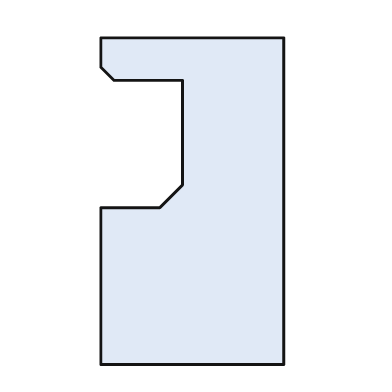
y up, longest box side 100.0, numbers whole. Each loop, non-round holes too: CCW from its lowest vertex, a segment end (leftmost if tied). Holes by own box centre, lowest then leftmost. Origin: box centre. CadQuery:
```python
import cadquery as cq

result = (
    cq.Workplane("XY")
    .moveTo(-28.0, -50.0)
    .lineTo(28.0, -50.0)
    .lineTo(28.0, 50.0)
    .lineTo(-28.0, 50.0)
    .lineTo(-28.0, 41.0)
    .lineTo(-24.0, 37.0)
    .lineTo(-3.0, 37.0)
    .lineTo(-3.0, 5.0)
    .lineTo(-10.0, -2.0)
    .lineTo(-28.0, -2.0)
    .close()
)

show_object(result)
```